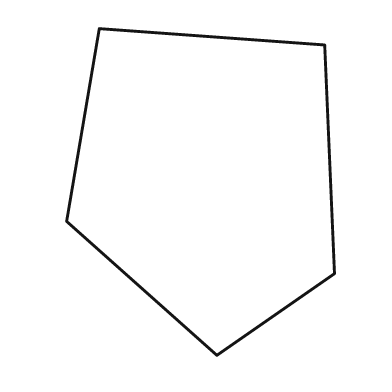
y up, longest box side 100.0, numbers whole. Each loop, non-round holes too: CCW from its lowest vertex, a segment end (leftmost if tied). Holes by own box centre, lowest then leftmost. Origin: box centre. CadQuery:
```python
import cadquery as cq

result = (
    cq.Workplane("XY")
    .moveTo(5.0, -50.0)
    .lineTo(41.0, -25.0)
    .lineTo(38.0, 45.0)
    .lineTo(-31.0, 50.0)
    .lineTo(-41.0, -9.0)
    .close()
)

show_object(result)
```